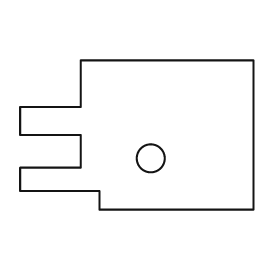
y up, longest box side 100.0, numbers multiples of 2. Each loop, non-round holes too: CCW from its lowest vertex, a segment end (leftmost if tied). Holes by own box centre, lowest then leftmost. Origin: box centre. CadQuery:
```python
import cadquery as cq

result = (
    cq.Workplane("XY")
    .moveTo(-16.0, -32.0)
    .lineTo(50.0, -32.0)
    .lineTo(50.0, 32.0)
    .lineTo(-24.0, 32.0)
    .lineTo(-24.0, 12.0)
    .lineTo(-50.0, 12.0)
    .lineTo(-50.0, 0.0)
    .lineTo(-24.0, 0.0)
    .lineTo(-24.0, -14.0)
    .lineTo(-50.0, -14.0)
    .lineTo(-50.0, -24.0)
    .lineTo(-16.0, -24.0)
    .close()
    .moveTo(6.0, -10.0)
    .circle(6.0)
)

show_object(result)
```